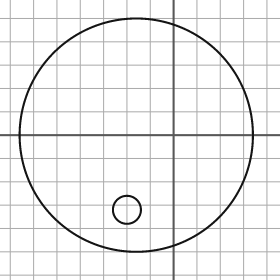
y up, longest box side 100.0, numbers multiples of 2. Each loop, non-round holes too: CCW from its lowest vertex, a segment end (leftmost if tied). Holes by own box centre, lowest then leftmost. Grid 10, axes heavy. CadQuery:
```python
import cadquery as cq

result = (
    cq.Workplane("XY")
    .moveTo(-16.0, 0.0)
    .circle(50.0)
    .moveTo(-20.0, -32.0)
    .circle(6.0)
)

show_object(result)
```